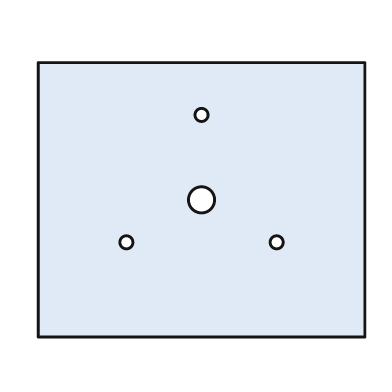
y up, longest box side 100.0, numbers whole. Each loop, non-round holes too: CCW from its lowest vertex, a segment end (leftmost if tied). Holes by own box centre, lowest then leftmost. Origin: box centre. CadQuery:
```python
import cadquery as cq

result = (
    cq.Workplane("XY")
    .moveTo(-50.0, -42.0)
    .lineTo(50.0, -42.0)
    .lineTo(50.0, 42.0)
    .lineTo(-50.0, 42.0)
    .close()
    .moveTo(-23.0, -13.0)
    .circle(2.0)
    .moveTo(23.0, -13.0)
    .circle(2.0)
    .moveTo(0.0, 0.0)
    .circle(4.0)
    .moveTo(0.0, 26.0)
    .circle(2.0)
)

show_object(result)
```